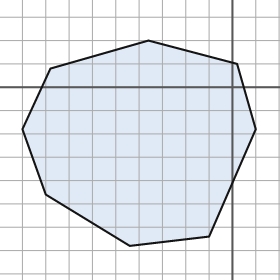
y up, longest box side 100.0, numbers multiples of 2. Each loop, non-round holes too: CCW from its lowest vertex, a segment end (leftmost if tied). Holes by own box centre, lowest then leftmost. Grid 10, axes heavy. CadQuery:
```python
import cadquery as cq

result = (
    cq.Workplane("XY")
    .moveTo(-44.0, -68.0)
    .lineTo(-10.0, -64.0)
    .lineTo(10.0, -18.0)
    .lineTo(2.0, 10.0)
    .lineTo(-36.0, 20.0)
    .lineTo(-78.0, 8.0)
    .lineTo(-90.0, -18.0)
    .lineTo(-80.0, -46.0)
    .close()
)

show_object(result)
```